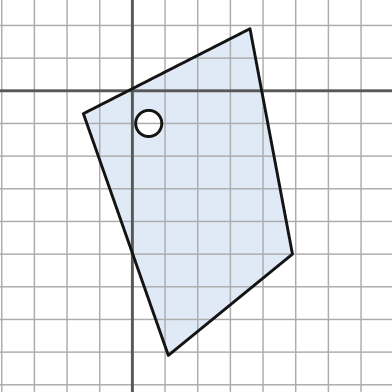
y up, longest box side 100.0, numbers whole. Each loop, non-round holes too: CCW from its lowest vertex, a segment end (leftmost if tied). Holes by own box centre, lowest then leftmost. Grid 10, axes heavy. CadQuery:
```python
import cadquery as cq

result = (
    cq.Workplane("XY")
    .moveTo(11.0, -81.0)
    .lineTo(49.0, -50.0)
    .lineTo(36.0, 19.0)
    .lineTo(-15.0, -7.0)
    .close()
    .moveTo(5.0, -10.0)
    .circle(4.0)
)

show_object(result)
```